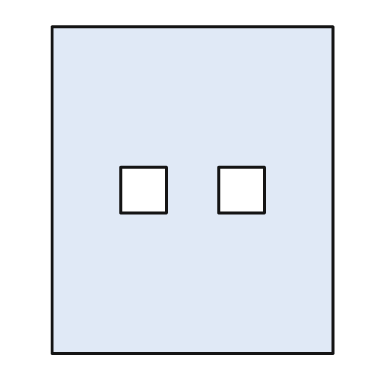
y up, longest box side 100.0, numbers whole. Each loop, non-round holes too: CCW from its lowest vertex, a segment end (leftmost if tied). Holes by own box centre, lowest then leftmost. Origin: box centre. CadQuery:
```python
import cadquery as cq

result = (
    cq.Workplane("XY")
    .moveTo(-43.0, -50.0)
    .lineTo(43.0, -50.0)
    .lineTo(43.0, 50.0)
    .lineTo(-43.0, 50.0)
    .close()
    .moveTo(-22.0, -7.0)
    .lineTo(-8.0, -7.0)
    .lineTo(-8.0, 7.0)
    .lineTo(-22.0, 7.0)
    .close()
    .moveTo(8.0, -7.0)
    .lineTo(22.0, -7.0)
    .lineTo(22.0, 7.0)
    .lineTo(8.0, 7.0)
    .close()
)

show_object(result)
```